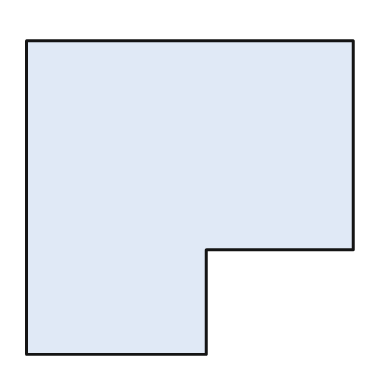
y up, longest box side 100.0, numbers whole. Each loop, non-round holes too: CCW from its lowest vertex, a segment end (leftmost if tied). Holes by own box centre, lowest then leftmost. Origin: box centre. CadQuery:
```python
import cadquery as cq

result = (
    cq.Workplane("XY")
    .moveTo(-50.0, -48.0)
    .lineTo(5.0, -48.0)
    .lineTo(5.0, -16.0)
    .lineTo(50.0, -16.0)
    .lineTo(50.0, 48.0)
    .lineTo(-50.0, 48.0)
    .close()
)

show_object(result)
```